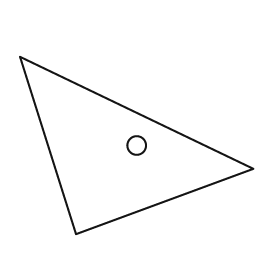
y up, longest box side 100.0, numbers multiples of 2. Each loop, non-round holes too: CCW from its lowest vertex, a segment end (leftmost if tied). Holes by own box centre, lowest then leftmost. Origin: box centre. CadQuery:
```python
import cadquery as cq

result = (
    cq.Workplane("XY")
    .moveTo(-26.0, -38.0)
    .lineTo(50.0, -10.0)
    .lineTo(-50.0, 38.0)
    .close()
    .moveTo(0.0, 0.0)
    .circle(4.0)
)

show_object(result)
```